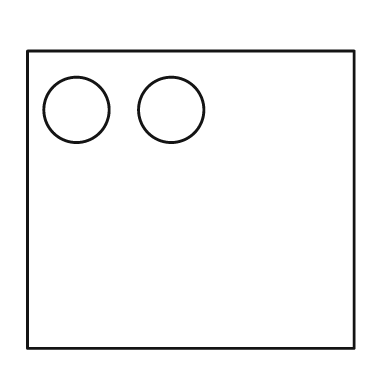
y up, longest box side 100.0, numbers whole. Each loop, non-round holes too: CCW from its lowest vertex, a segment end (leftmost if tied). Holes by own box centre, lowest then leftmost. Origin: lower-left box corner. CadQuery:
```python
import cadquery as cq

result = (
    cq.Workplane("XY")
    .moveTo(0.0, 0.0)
    .lineTo(100.0, 0.0)
    .lineTo(100.0, 91.0)
    .lineTo(0.0, 91.0)
    .close()
    .moveTo(15.0, 73.0)
    .circle(10.0)
    .moveTo(44.0, 73.0)
    .circle(10.0)
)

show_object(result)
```